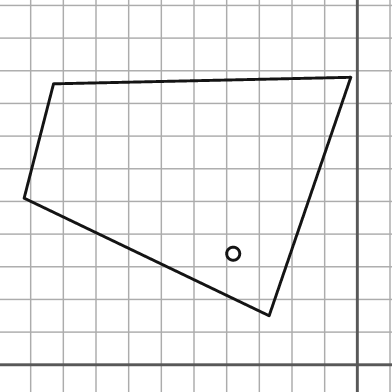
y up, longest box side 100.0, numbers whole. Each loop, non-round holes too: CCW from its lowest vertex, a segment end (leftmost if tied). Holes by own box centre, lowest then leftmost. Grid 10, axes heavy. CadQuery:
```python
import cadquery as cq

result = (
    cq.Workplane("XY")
    .moveTo(-27.0, 15.0)
    .lineTo(-2.0, 88.0)
    .lineTo(-93.0, 86.0)
    .lineTo(-102.0, 51.0)
    .close()
    .moveTo(-38.0, 34.0)
    .circle(2.0)
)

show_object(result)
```